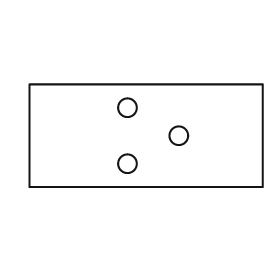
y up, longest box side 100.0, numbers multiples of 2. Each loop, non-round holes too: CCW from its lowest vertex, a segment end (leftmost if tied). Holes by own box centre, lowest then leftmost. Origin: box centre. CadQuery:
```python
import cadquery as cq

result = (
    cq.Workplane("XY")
    .moveTo(-50.0, -22.0)
    .lineTo(50.0, -22.0)
    .lineTo(50.0, 22.0)
    .lineTo(-50.0, 22.0)
    .close()
    .moveTo(-8.0, -12.0)
    .circle(4.0)
    .moveTo(14.0, 0.0)
    .circle(4.0)
    .moveTo(-8.0, 12.0)
    .circle(4.0)
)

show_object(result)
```